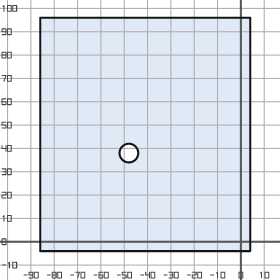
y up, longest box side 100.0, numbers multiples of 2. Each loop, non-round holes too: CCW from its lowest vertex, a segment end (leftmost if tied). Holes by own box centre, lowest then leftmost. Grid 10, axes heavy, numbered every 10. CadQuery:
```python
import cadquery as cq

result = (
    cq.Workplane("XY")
    .moveTo(-86.0, -4.0)
    .lineTo(4.0, -4.0)
    .lineTo(4.0, 96.0)
    .lineTo(-86.0, 96.0)
    .close()
    .moveTo(-48.0, 38.0)
    .circle(4.0)
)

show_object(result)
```